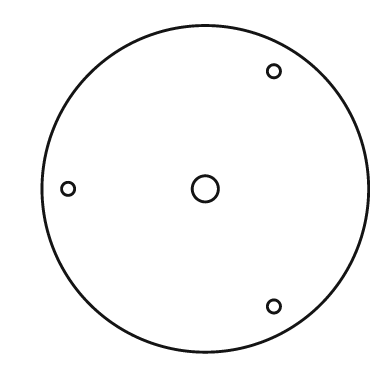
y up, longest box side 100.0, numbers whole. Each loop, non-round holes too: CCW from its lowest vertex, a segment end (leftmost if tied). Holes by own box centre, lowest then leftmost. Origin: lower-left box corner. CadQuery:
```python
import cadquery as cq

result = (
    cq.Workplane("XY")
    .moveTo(50.0, 50.0)
    .circle(50.0)
    .moveTo(71.0, 14.0)
    .circle(2.0)
    .moveTo(8.0, 50.0)
    .circle(2.0)
    .moveTo(50.0, 50.0)
    .circle(4.0)
    .moveTo(71.0, 86.0)
    .circle(2.0)
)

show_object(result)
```